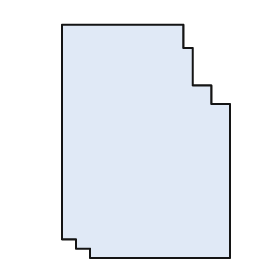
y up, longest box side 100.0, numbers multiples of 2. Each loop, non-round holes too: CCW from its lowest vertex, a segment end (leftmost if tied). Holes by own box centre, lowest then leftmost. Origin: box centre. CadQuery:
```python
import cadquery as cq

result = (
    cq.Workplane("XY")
    .moveTo(-24.0, -50.0)
    .lineTo(36.0, -50.0)
    .lineTo(36.0, 16.0)
    .lineTo(28.0, 16.0)
    .lineTo(28.0, 24.0)
    .lineTo(20.0, 24.0)
    .lineTo(20.0, 40.0)
    .lineTo(16.0, 40.0)
    .lineTo(16.0, 50.0)
    .lineTo(-36.0, 50.0)
    .lineTo(-36.0, -42.0)
    .lineTo(-30.0, -42.0)
    .lineTo(-30.0, -46.0)
    .lineTo(-24.0, -46.0)
    .close()
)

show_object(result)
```